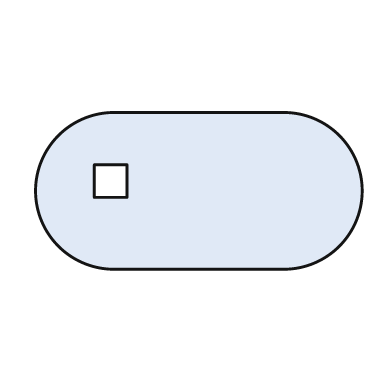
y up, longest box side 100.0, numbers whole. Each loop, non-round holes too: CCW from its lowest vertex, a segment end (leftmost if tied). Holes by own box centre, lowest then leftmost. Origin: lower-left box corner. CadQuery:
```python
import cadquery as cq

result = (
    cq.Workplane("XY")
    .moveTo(24.0, 0.0)
    .lineTo(76.0, 0.0)
    .threePointArc((100.0, 24.0), (76.0, 48.0))
    .lineTo(24.0, 48.0)
    .threePointArc((0.0, 24.0), (24.0, 0.0))
    .close()
    .moveTo(18.0, 22.0)
    .lineTo(28.0, 22.0)
    .lineTo(28.0, 32.0)
    .lineTo(18.0, 32.0)
    .close()
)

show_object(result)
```